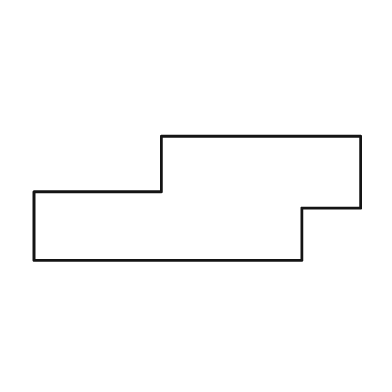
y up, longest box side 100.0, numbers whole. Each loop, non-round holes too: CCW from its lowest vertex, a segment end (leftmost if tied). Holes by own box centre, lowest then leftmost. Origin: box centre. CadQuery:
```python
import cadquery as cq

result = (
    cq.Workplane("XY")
    .moveTo(-50.0, -19.0)
    .lineTo(32.0, -19.0)
    .lineTo(32.0, -3.0)
    .lineTo(50.0, -3.0)
    .lineTo(50.0, 19.0)
    .lineTo(-11.0, 19.0)
    .lineTo(-11.0, 2.0)
    .lineTo(-50.0, 2.0)
    .close()
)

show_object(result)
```